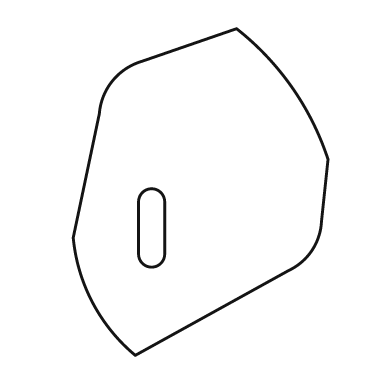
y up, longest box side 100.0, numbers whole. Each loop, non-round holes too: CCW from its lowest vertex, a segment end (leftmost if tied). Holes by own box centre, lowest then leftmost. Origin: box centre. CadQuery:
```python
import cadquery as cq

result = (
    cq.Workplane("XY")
    .moveTo(-20.0, -50.0)
    .lineTo(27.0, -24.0)
    .threePointArc((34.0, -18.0), (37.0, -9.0))
    .lineTo(39.0, 10.0)
    .threePointArc((28.0, 32.0), (11.0, 50.0))
    .lineTo(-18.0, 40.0)
    .threePointArc((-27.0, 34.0), (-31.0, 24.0))
    .lineTo(-39.0, -14.0)
    .threePointArc((-33.0, -34.0), (-20.0, -50.0))
    .close()
    .moveTo(-19.0, -19.0)
    .threePointArc((-15.0, -23.0), (-11.0, -19.0))
    .lineTo(-11.0, -3.0)
    .threePointArc((-15.0, 1.0), (-19.0, -3.0))
    .close()
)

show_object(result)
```